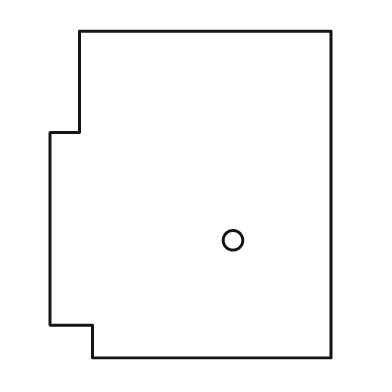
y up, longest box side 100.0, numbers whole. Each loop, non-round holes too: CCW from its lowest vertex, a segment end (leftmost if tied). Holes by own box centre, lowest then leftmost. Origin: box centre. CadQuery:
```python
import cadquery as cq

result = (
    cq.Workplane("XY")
    .moveTo(-30.0, -50.0)
    .lineTo(43.0, -50.0)
    .lineTo(43.0, 50.0)
    .lineTo(-34.0, 50.0)
    .lineTo(-34.0, 19.0)
    .lineTo(-43.0, 19.0)
    .lineTo(-43.0, -40.0)
    .lineTo(-30.0, -40.0)
    .close()
    .moveTo(13.0, -14.0)
    .circle(3.0)
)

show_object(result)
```